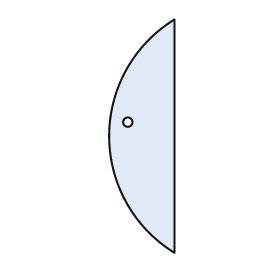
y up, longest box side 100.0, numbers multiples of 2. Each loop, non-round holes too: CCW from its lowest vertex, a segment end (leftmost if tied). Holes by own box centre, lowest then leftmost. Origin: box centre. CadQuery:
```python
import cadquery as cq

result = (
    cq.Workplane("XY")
    .moveTo(14.0, -50.0)
    .lineTo(14.0, 50.0)
    .threePointArc((-14.0, 0.0), (14.0, -50.0))
    .close()
    .moveTo(-6.0, 6.0)
    .circle(2.0)
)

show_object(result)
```